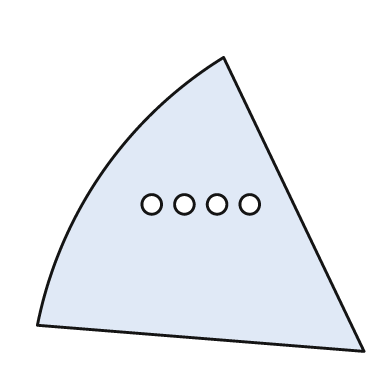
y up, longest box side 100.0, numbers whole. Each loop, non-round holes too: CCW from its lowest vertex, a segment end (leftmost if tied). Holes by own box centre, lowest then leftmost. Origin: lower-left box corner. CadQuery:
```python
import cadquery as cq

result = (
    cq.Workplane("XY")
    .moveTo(100.0, 0.0)
    .lineTo(57.0, 90.0)
    .threePointArc((20.0, 55.0), (0.0, 8.0))
    .close()
    .moveTo(35.0, 45.0)
    .circle(3.0)
    .moveTo(45.0, 45.0)
    .circle(3.0)
    .moveTo(55.0, 45.0)
    .circle(3.0)
    .moveTo(65.0, 45.0)
    .circle(3.0)
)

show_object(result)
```